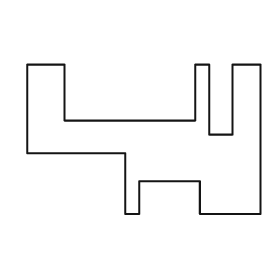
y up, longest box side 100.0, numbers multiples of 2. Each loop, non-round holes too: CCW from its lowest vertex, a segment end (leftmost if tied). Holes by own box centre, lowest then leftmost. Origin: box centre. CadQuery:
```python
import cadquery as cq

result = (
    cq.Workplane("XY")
    .moveTo(-8.0, -32.0)
    .lineTo(-2.0, -32.0)
    .lineTo(-2.0, -18.0)
    .lineTo(24.0, -18.0)
    .lineTo(24.0, -32.0)
    .lineTo(50.0, -32.0)
    .lineTo(50.0, 32.0)
    .lineTo(38.0, 32.0)
    .lineTo(38.0, 2.0)
    .lineTo(28.0, 2.0)
    .lineTo(28.0, 32.0)
    .lineTo(22.0, 32.0)
    .lineTo(22.0, 8.0)
    .lineTo(-34.0, 8.0)
    .lineTo(-34.0, 32.0)
    .lineTo(-50.0, 32.0)
    .lineTo(-50.0, -6.0)
    .lineTo(-8.0, -6.0)
    .close()
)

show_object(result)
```